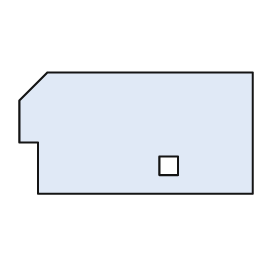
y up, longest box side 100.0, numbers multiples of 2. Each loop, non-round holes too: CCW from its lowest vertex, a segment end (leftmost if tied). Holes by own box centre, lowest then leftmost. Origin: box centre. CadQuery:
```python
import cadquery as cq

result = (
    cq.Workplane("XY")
    .moveTo(-42.0, -26.0)
    .lineTo(50.0, -26.0)
    .lineTo(50.0, 26.0)
    .lineTo(-38.0, 26.0)
    .lineTo(-50.0, 14.0)
    .lineTo(-50.0, -4.0)
    .lineTo(-42.0, -4.0)
    .close()
    .moveTo(10.0, -18.0)
    .lineTo(18.0, -18.0)
    .lineTo(18.0, -10.0)
    .lineTo(10.0, -10.0)
    .close()
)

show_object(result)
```